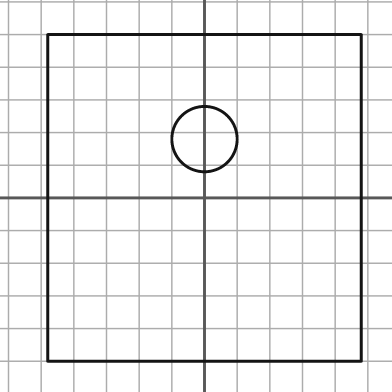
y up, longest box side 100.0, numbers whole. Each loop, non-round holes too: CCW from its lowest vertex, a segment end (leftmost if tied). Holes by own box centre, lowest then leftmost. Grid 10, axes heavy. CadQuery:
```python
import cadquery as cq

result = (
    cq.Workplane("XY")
    .moveTo(-48.0, -50.0)
    .lineTo(48.0, -50.0)
    .lineTo(48.0, 50.0)
    .lineTo(-48.0, 50.0)
    .close()
    .moveTo(0.0, 18.0)
    .circle(10.0)
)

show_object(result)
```